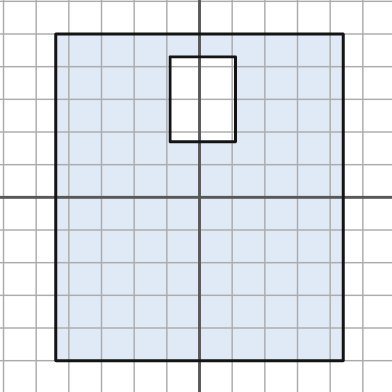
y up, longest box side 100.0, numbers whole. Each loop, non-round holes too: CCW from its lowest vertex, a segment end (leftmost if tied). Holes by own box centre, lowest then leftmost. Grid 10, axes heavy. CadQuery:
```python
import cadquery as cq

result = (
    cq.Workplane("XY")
    .moveTo(-44.0, -50.0)
    .lineTo(44.0, -50.0)
    .lineTo(44.0, 50.0)
    .lineTo(-44.0, 50.0)
    .close()
    .moveTo(-9.0, 17.0)
    .lineTo(11.0, 17.0)
    .lineTo(11.0, 43.0)
    .lineTo(-9.0, 43.0)
    .close()
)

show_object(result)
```